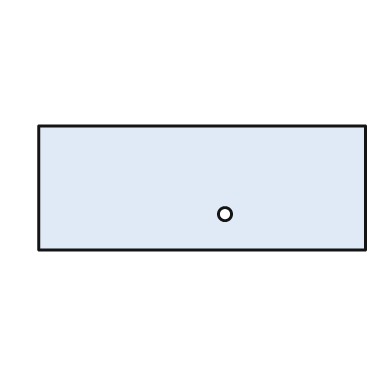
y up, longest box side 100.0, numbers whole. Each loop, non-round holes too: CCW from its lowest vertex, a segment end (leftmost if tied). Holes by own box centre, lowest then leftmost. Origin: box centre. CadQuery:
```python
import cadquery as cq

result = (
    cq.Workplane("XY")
    .moveTo(-50.0, -19.0)
    .lineTo(50.0, -19.0)
    .lineTo(50.0, 19.0)
    .lineTo(-50.0, 19.0)
    .close()
    .moveTo(7.0, -8.0)
    .circle(2.0)
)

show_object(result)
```